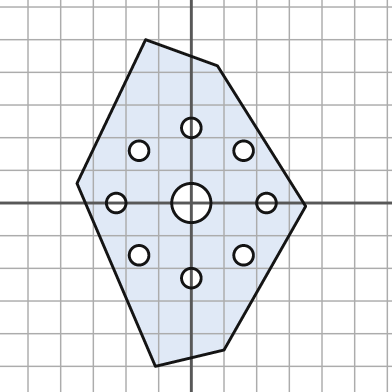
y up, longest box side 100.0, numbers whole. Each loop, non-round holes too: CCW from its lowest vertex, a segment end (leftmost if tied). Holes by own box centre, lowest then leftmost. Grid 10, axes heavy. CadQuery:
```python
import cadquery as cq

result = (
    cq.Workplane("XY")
    .moveTo(-11.0, -50.0)
    .lineTo(10.0, -45.0)
    .lineTo(35.0, -1.0)
    .lineTo(8.0, 42.0)
    .lineTo(-14.0, 50.0)
    .lineTo(-35.0, 6.0)
    .close()
    .moveTo(0.0, -23.0)
    .circle(3.0)
    .moveTo(-16.0, -16.0)
    .circle(3.0)
    .moveTo(16.0, -16.0)
    .circle(3.0)
    .moveTo(-23.0, 0.0)
    .circle(3.0)
    .moveTo(0.0, 0.0)
    .circle(6.0)
    .moveTo(23.0, 0.0)
    .circle(3.0)
    .moveTo(-16.0, 16.0)
    .circle(3.0)
    .moveTo(16.0, 16.0)
    .circle(3.0)
    .moveTo(0.0, 23.0)
    .circle(3.0)
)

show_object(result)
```